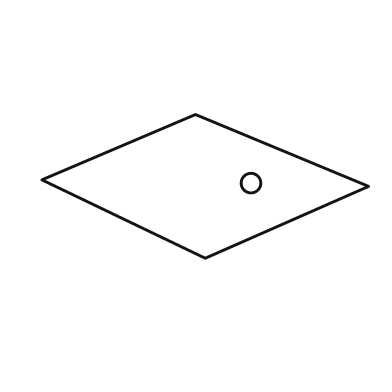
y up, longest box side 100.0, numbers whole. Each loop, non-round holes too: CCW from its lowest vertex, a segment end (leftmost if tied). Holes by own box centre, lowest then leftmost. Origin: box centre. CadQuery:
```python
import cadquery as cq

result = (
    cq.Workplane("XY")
    .moveTo(0.0, -22.0)
    .lineTo(50.0, 0.0)
    .lineTo(-3.0, 22.0)
    .lineTo(-50.0, 2.0)
    .close()
    .moveTo(14.0, 1.0)
    .circle(3.0)
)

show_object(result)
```